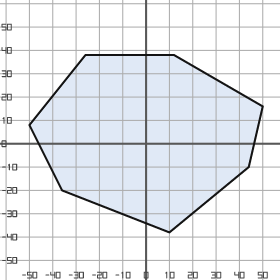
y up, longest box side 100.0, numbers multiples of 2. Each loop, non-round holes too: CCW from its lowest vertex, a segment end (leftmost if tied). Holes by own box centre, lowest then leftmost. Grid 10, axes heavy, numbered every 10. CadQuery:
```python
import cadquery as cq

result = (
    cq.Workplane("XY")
    .moveTo(10.0, -38.0)
    .lineTo(44.0, -10.0)
    .lineTo(50.0, 16.0)
    .lineTo(12.0, 38.0)
    .lineTo(-26.0, 38.0)
    .lineTo(-50.0, 8.0)
    .lineTo(-36.0, -20.0)
    .close()
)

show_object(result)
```